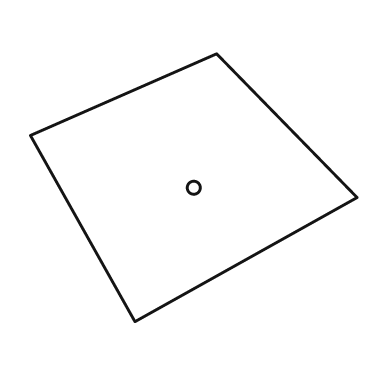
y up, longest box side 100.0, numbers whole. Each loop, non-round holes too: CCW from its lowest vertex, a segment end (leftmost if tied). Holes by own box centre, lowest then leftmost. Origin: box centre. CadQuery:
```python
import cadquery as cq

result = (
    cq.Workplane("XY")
    .moveTo(-18.0, -41.0)
    .lineTo(50.0, -3.0)
    .lineTo(7.0, 41.0)
    .lineTo(-50.0, 16.0)
    .close()
    .moveTo(0.0, 0.0)
    .circle(2.0)
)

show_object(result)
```